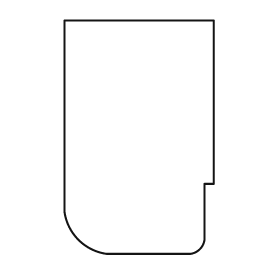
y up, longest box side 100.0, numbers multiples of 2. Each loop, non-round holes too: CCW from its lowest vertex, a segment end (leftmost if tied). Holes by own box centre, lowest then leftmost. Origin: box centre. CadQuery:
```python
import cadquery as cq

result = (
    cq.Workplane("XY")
    .moveTo(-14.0, -50.0)
    .lineTo(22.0, -50.0)
    .threePointArc((26.0, -48.0), (28.0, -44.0))
    .lineTo(28.0, -20.0)
    .lineTo(32.0, -20.0)
    .lineTo(32.0, 50.0)
    .lineTo(-32.0, 50.0)
    .lineTo(-32.0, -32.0)
    .threePointArc((-26.0, -44.0), (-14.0, -50.0))
    .close()
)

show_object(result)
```